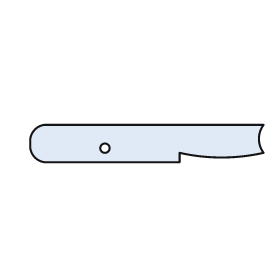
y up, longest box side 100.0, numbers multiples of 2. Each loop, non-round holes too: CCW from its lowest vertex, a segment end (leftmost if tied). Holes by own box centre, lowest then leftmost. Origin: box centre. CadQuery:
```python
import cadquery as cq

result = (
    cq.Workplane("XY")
    .moveTo(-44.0, -8.0)
    .lineTo(14.0, -8.0)
    .lineTo(14.0, -4.0)
    .threePointArc((32.0, -6.0), (50.0, -4.0))
    .threePointArc((48.0, 2.0), (50.0, 8.0))
    .lineTo(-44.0, 8.0)
    .threePointArc((-48.0, 6.0), (-50.0, 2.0))
    .lineTo(-50.0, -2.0)
    .threePointArc((-48.0, -6.0), (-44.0, -8.0))
    .close()
    .moveTo(-18.0, -2.0)
    .circle(2.0)
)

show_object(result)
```